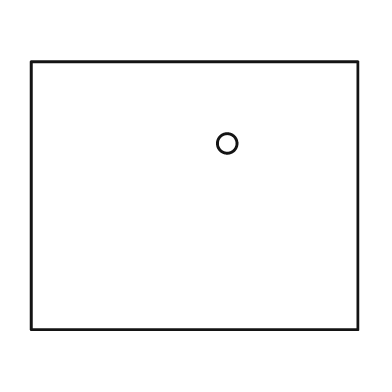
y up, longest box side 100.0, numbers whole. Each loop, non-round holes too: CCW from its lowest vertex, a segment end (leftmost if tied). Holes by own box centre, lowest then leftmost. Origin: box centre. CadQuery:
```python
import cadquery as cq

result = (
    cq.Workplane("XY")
    .moveTo(-50.0, -41.0)
    .lineTo(50.0, -41.0)
    .lineTo(50.0, 41.0)
    .lineTo(-50.0, 41.0)
    .close()
    .moveTo(10.0, 16.0)
    .circle(3.0)
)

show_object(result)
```